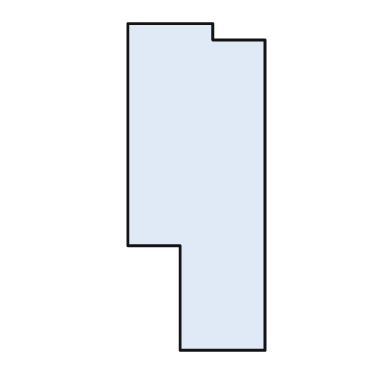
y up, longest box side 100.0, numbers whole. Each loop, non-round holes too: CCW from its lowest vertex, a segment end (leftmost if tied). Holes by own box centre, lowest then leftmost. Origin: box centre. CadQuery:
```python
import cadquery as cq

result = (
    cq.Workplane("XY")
    .moveTo(-5.0, -50.0)
    .lineTo(21.0, -50.0)
    .lineTo(21.0, 45.0)
    .lineTo(5.0, 45.0)
    .lineTo(5.0, 50.0)
    .lineTo(-21.0, 50.0)
    .lineTo(-21.0, -18.0)
    .lineTo(-5.0, -18.0)
    .close()
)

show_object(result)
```